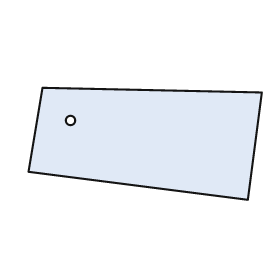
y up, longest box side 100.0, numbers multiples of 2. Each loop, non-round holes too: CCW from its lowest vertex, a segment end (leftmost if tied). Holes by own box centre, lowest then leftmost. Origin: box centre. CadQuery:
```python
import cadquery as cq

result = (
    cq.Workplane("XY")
    .moveTo(44.0, -24.0)
    .lineTo(50.0, 22.0)
    .lineTo(-44.0, 24.0)
    .lineTo(-50.0, -12.0)
    .close()
    .moveTo(-32.0, 10.0)
    .circle(2.0)
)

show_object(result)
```